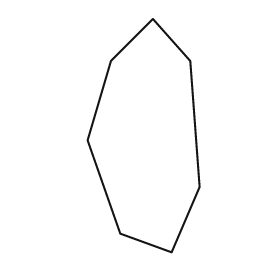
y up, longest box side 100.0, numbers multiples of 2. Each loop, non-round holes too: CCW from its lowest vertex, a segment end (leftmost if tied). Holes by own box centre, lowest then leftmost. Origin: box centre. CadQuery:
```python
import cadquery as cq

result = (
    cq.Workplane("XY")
    .moveTo(12.0, -50.0)
    .lineTo(24.0, -22.0)
    .lineTo(20.0, 32.0)
    .lineTo(4.0, 50.0)
    .lineTo(-14.0, 32.0)
    .lineTo(-24.0, -2.0)
    .lineTo(-10.0, -42.0)
    .close()
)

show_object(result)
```